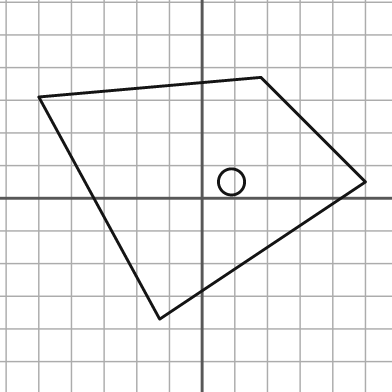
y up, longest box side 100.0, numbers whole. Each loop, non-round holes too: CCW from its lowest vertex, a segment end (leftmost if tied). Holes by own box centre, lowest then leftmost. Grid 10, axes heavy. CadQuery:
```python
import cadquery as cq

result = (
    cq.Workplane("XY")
    .moveTo(-13.0, -37.0)
    .lineTo(50.0, 5.0)
    .lineTo(18.0, 37.0)
    .lineTo(-50.0, 31.0)
    .close()
    .moveTo(9.0, 5.0)
    .circle(4.0)
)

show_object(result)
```